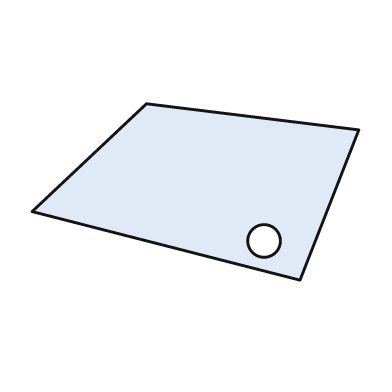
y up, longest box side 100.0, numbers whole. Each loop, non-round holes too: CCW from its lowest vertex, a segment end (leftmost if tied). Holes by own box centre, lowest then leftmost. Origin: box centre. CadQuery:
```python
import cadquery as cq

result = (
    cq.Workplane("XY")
    .moveTo(32.0, -27.0)
    .lineTo(50.0, 19.0)
    .lineTo(-15.0, 27.0)
    .lineTo(-50.0, -6.0)
    .close()
    .moveTo(21.0, -15.0)
    .circle(5.0)
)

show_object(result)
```